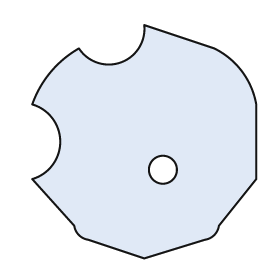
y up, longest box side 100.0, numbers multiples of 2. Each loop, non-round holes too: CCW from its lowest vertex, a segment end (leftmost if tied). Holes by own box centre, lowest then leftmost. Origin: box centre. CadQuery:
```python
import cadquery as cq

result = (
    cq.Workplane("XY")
    .moveTo(0.0, -50.0)
    .lineTo(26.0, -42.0)
    .threePointArc((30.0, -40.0), (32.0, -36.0))
    .lineTo(48.0, -16.0)
    .lineTo(48.0, 16.0)
    .threePointArc((42.0, 30.0), (30.0, 40.0))
    .lineTo(0.0, 50.0)
    .threePointArc((-10.0, 34.0), (-28.0, 40.0))
    .threePointArc((-40.0, 30.0), (-48.0, 16.0))
    .threePointArc((-36.0, 0.0), (-48.0, -16.0))
    .lineTo(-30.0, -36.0)
    .threePointArc((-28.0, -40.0), (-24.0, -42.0))
    .close()
    .moveTo(8.0, -12.0)
    .circle(6.0)
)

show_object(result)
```